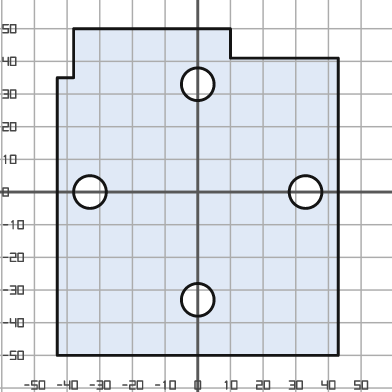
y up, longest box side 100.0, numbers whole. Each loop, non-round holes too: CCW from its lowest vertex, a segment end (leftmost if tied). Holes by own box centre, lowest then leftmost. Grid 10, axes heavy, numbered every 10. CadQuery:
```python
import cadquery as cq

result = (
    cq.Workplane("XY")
    .moveTo(-43.0, -50.0)
    .lineTo(43.0, -50.0)
    .lineTo(43.0, 41.0)
    .lineTo(10.0, 41.0)
    .lineTo(10.0, 50.0)
    .lineTo(-38.0, 50.0)
    .lineTo(-38.0, 35.0)
    .lineTo(-43.0, 35.0)
    .close()
    .moveTo(0.0, -33.0)
    .circle(5.0)
    .moveTo(-33.0, 0.0)
    .circle(5.0)
    .moveTo(33.0, 0.0)
    .circle(5.0)
    .moveTo(0.0, 33.0)
    .circle(5.0)
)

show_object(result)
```